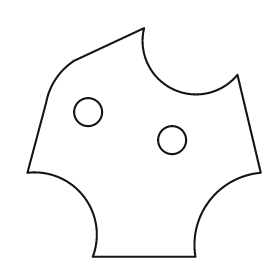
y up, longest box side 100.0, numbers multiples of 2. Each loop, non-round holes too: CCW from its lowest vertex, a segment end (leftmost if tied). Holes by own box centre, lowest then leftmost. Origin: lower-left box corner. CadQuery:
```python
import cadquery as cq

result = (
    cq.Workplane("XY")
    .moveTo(28.0, 0.0)
    .lineTo(72.0, 0.0)
    .threePointArc((78.0, 24.0), (100.0, 36.0))
    .lineTo(90.0, 78.0)
    .threePointArc((62.0, 72.0), (50.0, 98.0))
    .lineTo(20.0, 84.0)
    .threePointArc((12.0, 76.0), (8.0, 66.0))
    .lineTo(0.0, 36.0)
    .threePointArc((24.0, 26.0), (28.0, 0.0))
    .close()
    .moveTo(62.0, 50.0)
    .circle(6.0)
    .moveTo(26.0, 62.0)
    .circle(6.0)
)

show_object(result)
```